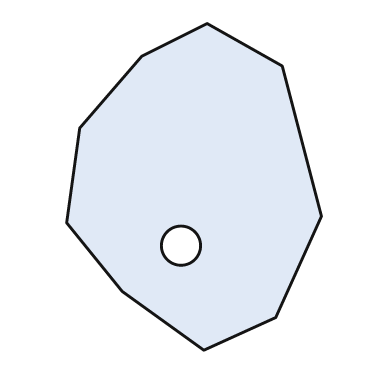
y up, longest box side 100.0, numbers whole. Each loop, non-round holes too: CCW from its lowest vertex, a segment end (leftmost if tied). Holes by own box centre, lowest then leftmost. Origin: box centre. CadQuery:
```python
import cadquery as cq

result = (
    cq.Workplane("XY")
    .moveTo(3.0, -50.0)
    .lineTo(25.0, -40.0)
    .lineTo(39.0, -9.0)
    .lineTo(27.0, 37.0)
    .lineTo(4.0, 50.0)
    .lineTo(-16.0, 40.0)
    .lineTo(-35.0, 18.0)
    .lineTo(-39.0, -11.0)
    .lineTo(-22.0, -32.0)
    .close()
    .moveTo(-4.0, -18.0)
    .circle(6.0)
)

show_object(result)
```